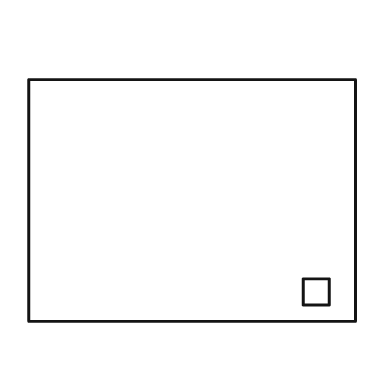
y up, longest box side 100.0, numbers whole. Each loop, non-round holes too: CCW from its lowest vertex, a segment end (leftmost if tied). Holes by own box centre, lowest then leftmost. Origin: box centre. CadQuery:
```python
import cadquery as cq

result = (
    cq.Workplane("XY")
    .moveTo(-50.0, -37.0)
    .lineTo(50.0, -37.0)
    .lineTo(50.0, 37.0)
    .lineTo(-50.0, 37.0)
    .close()
    .moveTo(34.0, -32.0)
    .lineTo(42.0, -32.0)
    .lineTo(42.0, -24.0)
    .lineTo(34.0, -24.0)
    .close()
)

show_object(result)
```